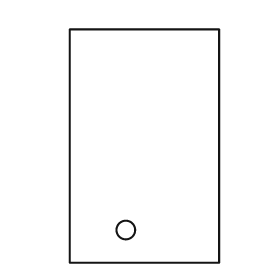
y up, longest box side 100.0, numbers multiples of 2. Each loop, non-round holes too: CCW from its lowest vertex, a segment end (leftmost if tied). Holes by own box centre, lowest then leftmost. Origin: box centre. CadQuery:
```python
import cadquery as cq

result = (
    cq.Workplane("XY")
    .moveTo(-32.0, -50.0)
    .lineTo(32.0, -50.0)
    .lineTo(32.0, 50.0)
    .lineTo(-32.0, 50.0)
    .close()
    .moveTo(-8.0, -36.0)
    .circle(4.0)
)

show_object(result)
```